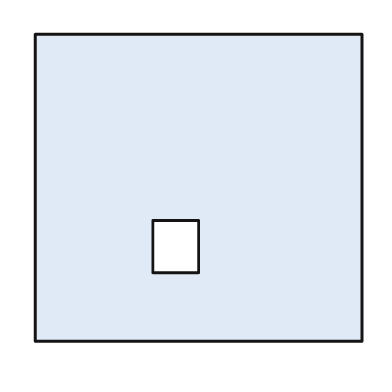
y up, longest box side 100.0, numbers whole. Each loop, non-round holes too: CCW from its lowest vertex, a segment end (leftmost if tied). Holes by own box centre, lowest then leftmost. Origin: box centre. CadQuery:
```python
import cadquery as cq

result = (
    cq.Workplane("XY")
    .moveTo(-50.0, -47.0)
    .lineTo(50.0, -47.0)
    .lineTo(50.0, 47.0)
    .lineTo(-50.0, 47.0)
    .close()
    .moveTo(-14.0, -26.0)
    .lineTo(0.0, -26.0)
    .lineTo(0.0, -10.0)
    .lineTo(-14.0, -10.0)
    .close()
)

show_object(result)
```